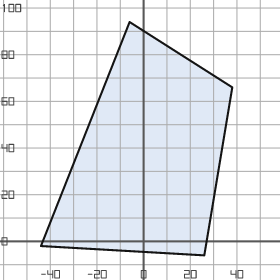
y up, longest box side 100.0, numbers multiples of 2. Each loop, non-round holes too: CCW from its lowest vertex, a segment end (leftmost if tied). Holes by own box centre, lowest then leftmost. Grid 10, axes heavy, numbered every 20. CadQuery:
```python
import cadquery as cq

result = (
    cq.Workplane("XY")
    .moveTo(26.0, -6.0)
    .lineTo(38.0, 66.0)
    .lineTo(-6.0, 94.0)
    .lineTo(-44.0, -2.0)
    .close()
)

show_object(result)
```